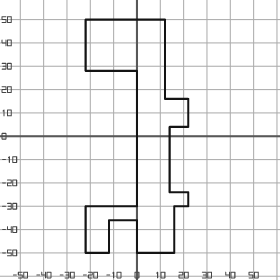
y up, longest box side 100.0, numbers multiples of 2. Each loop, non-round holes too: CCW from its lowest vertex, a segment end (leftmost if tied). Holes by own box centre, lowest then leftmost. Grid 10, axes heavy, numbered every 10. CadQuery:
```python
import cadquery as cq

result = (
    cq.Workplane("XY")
    .moveTo(-22.0, -50.0)
    .lineTo(-12.0, -50.0)
    .lineTo(-12.0, -36.0)
    .lineTo(0.0, -36.0)
    .lineTo(0.0, -50.0)
    .lineTo(16.0, -50.0)
    .lineTo(16.0, -30.0)
    .lineTo(22.0, -30.0)
    .lineTo(22.0, -24.0)
    .lineTo(14.0, -24.0)
    .lineTo(14.0, 4.0)
    .lineTo(22.0, 4.0)
    .lineTo(22.0, 16.0)
    .lineTo(12.0, 16.0)
    .lineTo(12.0, 50.0)
    .lineTo(-22.0, 50.0)
    .lineTo(-22.0, 28.0)
    .lineTo(0.0, 28.0)
    .lineTo(0.0, -30.0)
    .lineTo(-22.0, -30.0)
    .close()
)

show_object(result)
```